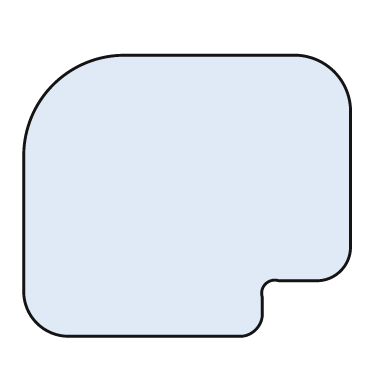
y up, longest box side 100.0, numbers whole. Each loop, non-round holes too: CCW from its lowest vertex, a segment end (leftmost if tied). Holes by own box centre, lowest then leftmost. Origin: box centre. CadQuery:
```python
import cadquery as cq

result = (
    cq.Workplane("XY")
    .moveTo(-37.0, -43.0)
    .lineTo(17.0, -43.0)
    .threePointArc((21.0, -41.0), (23.0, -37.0))
    .lineTo(23.0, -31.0)
    .threePointArc((24.0, -27.0), (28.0, -26.0))
    .lineTo(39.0, -26.0)
    .threePointArc((47.0, -23.0), (50.0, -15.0))
    .lineTo(50.0, 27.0)
    .threePointArc((45.0, 38.0), (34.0, 43.0))
    .lineTo(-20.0, 43.0)
    .threePointArc((-41.0, 34.0), (-50.0, 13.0))
    .lineTo(-50.0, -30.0)
    .threePointArc((-46.0, -39.0), (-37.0, -43.0))
    .close()
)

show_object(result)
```